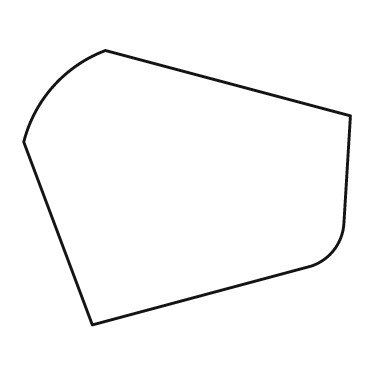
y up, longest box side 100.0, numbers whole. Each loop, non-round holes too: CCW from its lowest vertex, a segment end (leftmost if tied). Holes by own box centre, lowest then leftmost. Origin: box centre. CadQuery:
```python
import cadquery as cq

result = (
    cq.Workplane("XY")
    .moveTo(-29.0, -42.0)
    .lineTo(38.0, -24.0)
    .threePointArc((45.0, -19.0), (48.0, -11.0))
    .lineTo(50.0, 22.0)
    .lineTo(-25.0, 42.0)
    .threePointArc((-41.0, 31.0), (-50.0, 14.0))
    .close()
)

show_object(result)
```